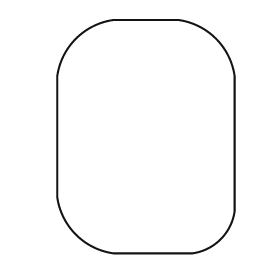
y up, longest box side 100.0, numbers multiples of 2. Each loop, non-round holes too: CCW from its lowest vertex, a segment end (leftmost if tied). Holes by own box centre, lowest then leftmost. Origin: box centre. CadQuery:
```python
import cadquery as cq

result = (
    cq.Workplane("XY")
    .moveTo(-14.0, -50.0)
    .lineTo(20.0, -50.0)
    .threePointArc((32.0, -44.0), (38.0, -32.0))
    .lineTo(38.0, 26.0)
    .threePointArc((30.0, 42.0), (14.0, 50.0))
    .lineTo(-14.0, 50.0)
    .threePointArc((-30.0, 42.0), (-38.0, 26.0))
    .lineTo(-38.0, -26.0)
    .threePointArc((-30.0, -42.0), (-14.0, -50.0))
    .close()
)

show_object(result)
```